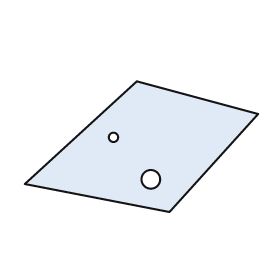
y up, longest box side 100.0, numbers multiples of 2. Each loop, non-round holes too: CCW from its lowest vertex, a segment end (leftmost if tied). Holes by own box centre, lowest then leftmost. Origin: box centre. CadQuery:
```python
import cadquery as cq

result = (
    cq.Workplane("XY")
    .moveTo(12.0, -28.0)
    .lineTo(50.0, 14.0)
    .lineTo(-2.0, 28.0)
    .lineTo(-50.0, -16.0)
    .close()
    .moveTo(4.0, -14.0)
    .circle(4.0)
    .moveTo(-12.0, 4.0)
    .circle(2.0)
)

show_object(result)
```